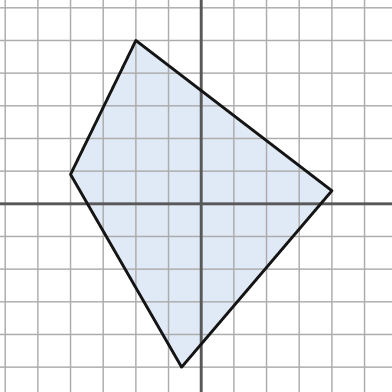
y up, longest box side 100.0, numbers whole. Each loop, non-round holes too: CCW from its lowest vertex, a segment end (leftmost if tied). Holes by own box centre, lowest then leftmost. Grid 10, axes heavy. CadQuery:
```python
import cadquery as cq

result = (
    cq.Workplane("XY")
    .moveTo(-6.0, -50.0)
    .lineTo(40.0, 4.0)
    .lineTo(-20.0, 50.0)
    .lineTo(-40.0, 9.0)
    .close()
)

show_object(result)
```